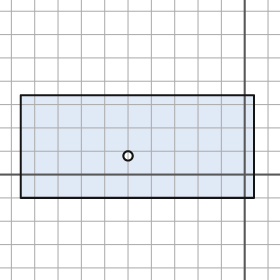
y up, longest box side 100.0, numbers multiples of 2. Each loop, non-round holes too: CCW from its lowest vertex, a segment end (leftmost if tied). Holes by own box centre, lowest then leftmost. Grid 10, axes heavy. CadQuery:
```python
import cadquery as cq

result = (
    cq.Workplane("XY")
    .moveTo(-96.0, -10.0)
    .lineTo(4.0, -10.0)
    .lineTo(4.0, 34.0)
    .lineTo(-96.0, 34.0)
    .close()
    .moveTo(-50.0, 8.0)
    .circle(2.0)
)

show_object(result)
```